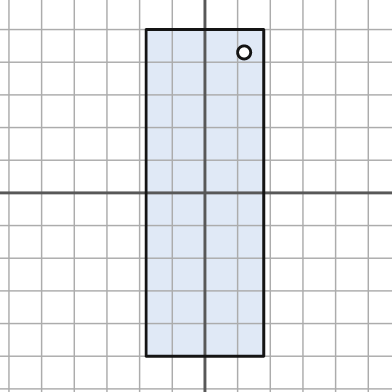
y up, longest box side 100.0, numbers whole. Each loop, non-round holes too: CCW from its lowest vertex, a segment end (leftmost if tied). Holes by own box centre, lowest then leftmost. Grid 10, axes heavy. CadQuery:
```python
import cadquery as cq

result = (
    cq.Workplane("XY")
    .moveTo(-18.0, -50.0)
    .lineTo(18.0, -50.0)
    .lineTo(18.0, 50.0)
    .lineTo(-18.0, 50.0)
    .close()
    .moveTo(12.0, 43.0)
    .circle(2.0)
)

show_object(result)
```